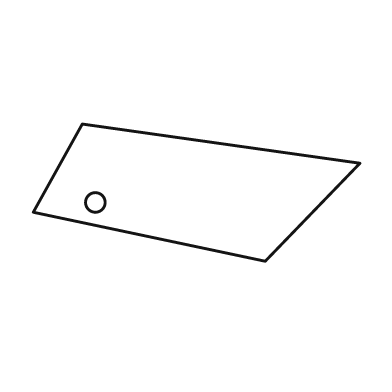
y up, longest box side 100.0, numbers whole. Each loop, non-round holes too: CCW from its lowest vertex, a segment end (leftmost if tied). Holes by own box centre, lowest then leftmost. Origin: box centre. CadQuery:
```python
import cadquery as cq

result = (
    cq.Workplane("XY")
    .moveTo(21.0, -21.0)
    .lineTo(50.0, 9.0)
    .lineTo(-35.0, 21.0)
    .lineTo(-50.0, -6.0)
    .close()
    .moveTo(-31.0, -3.0)
    .circle(3.0)
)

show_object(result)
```